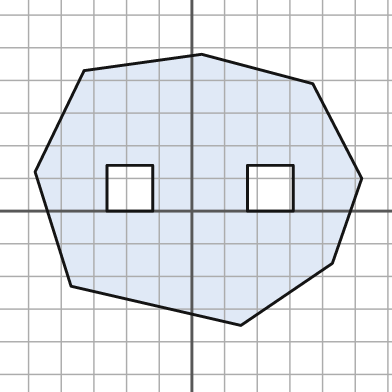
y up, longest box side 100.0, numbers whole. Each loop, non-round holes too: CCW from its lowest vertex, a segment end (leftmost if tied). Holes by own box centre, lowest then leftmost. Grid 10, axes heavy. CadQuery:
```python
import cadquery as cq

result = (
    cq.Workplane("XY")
    .moveTo(15.0, -35.0)
    .lineTo(43.0, -16.0)
    .lineTo(52.0, 10.0)
    .lineTo(37.0, 39.0)
    .lineTo(3.0, 48.0)
    .lineTo(-33.0, 43.0)
    .lineTo(-48.0, 12.0)
    .lineTo(-37.0, -23.0)
    .close()
    .moveTo(-26.0, 0.0)
    .lineTo(-12.0, 0.0)
    .lineTo(-12.0, 14.0)
    .lineTo(-26.0, 14.0)
    .close()
    .moveTo(17.0, 0.0)
    .lineTo(31.0, 0.0)
    .lineTo(31.0, 14.0)
    .lineTo(17.0, 14.0)
    .close()
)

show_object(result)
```